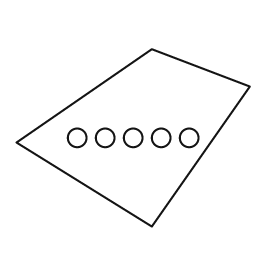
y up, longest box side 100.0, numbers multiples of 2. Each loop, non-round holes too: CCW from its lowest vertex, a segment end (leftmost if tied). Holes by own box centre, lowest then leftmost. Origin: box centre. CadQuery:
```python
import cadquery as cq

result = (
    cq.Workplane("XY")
    .moveTo(8.0, -38.0)
    .lineTo(50.0, 22.0)
    .lineTo(8.0, 38.0)
    .lineTo(-50.0, -2.0)
    .close()
    .moveTo(-24.0, 0.0)
    .circle(4.0)
    .moveTo(-12.0, 0.0)
    .circle(4.0)
    .moveTo(0.0, 0.0)
    .circle(4.0)
    .moveTo(12.0, 0.0)
    .circle(4.0)
    .moveTo(24.0, 0.0)
    .circle(4.0)
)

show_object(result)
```